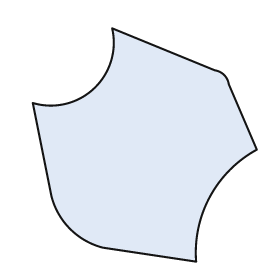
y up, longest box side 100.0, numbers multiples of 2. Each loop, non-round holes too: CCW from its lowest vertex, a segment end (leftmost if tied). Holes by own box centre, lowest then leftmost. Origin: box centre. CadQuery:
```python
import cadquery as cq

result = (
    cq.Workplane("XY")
    .moveTo(22.0, -50.0)
    .threePointArc((28.0, -22.0), (48.0, -2.0))
    .lineTo(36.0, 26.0)
    .threePointArc((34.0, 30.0), (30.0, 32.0))
    .lineTo(-14.0, 50.0)
    .threePointArc((-22.0, 24.0), (-48.0, 18.0))
    .lineTo(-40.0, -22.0)
    .threePointArc((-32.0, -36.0), (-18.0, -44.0))
    .close()
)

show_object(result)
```